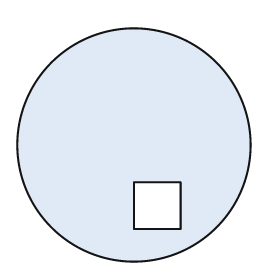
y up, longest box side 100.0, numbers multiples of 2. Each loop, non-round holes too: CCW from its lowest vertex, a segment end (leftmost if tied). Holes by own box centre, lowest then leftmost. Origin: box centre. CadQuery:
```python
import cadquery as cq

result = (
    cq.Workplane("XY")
    .moveTo(0.0, 0.0)
    .circle(50.0)
    .moveTo(0.0, -36.0)
    .lineTo(20.0, -36.0)
    .lineTo(20.0, -16.0)
    .lineTo(0.0, -16.0)
    .close()
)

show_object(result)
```